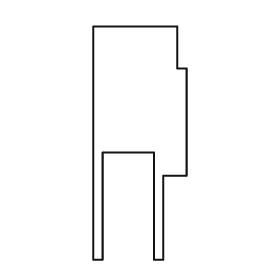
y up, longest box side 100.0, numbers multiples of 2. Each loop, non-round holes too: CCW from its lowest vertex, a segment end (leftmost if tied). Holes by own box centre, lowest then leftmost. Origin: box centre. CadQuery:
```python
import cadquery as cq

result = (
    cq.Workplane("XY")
    .moveTo(-20.0, -50.0)
    .lineTo(-16.0, -50.0)
    .lineTo(-16.0, -4.0)
    .lineTo(6.0, -4.0)
    .lineTo(6.0, -50.0)
    .lineTo(10.0, -50.0)
    .lineTo(10.0, -14.0)
    .lineTo(20.0, -14.0)
    .lineTo(20.0, 32.0)
    .lineTo(16.0, 32.0)
    .lineTo(16.0, 50.0)
    .lineTo(-20.0, 50.0)
    .close()
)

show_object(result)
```